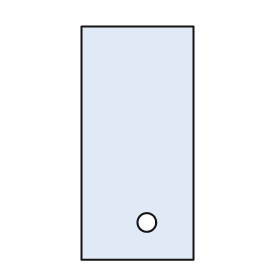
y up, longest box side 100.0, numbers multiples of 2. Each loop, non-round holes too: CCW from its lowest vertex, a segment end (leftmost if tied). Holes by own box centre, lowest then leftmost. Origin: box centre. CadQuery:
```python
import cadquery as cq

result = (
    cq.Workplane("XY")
    .moveTo(-24.0, -50.0)
    .lineTo(24.0, -50.0)
    .lineTo(24.0, 50.0)
    .lineTo(-24.0, 50.0)
    .close()
    .moveTo(4.0, -34.0)
    .circle(4.0)
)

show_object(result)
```